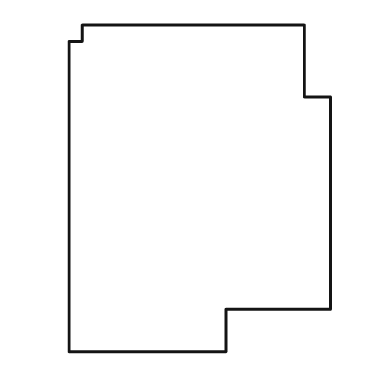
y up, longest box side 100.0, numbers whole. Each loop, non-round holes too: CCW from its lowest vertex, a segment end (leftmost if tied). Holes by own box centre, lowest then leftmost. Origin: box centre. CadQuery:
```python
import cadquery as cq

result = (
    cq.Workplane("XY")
    .moveTo(-40.0, -50.0)
    .lineTo(8.0, -50.0)
    .lineTo(8.0, -37.0)
    .lineTo(40.0, -37.0)
    .lineTo(40.0, 28.0)
    .lineTo(32.0, 28.0)
    .lineTo(32.0, 50.0)
    .lineTo(-36.0, 50.0)
    .lineTo(-36.0, 45.0)
    .lineTo(-40.0, 45.0)
    .close()
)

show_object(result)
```